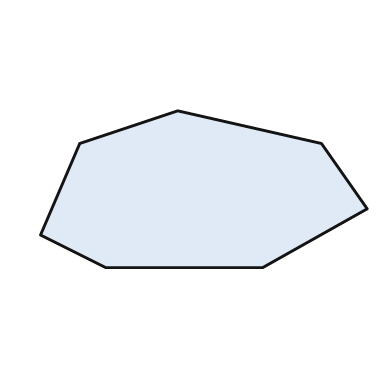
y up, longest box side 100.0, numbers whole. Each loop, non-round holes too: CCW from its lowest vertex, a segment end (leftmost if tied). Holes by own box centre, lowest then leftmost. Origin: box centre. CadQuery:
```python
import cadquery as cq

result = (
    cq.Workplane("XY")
    .moveTo(-30.0, -24.0)
    .lineTo(18.0, -24.0)
    .lineTo(50.0, -6.0)
    .lineTo(36.0, 14.0)
    .lineTo(-8.0, 24.0)
    .lineTo(-38.0, 14.0)
    .lineTo(-50.0, -14.0)
    .close()
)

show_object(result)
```